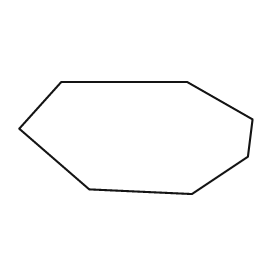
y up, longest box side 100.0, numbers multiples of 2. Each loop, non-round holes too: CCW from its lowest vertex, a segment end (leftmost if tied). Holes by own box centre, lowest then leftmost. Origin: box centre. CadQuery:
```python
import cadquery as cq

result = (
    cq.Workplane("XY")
    .moveTo(24.0, -24.0)
    .lineTo(48.0, -8.0)
    .lineTo(50.0, 8.0)
    .lineTo(22.0, 24.0)
    .lineTo(-32.0, 24.0)
    .lineTo(-50.0, 4.0)
    .lineTo(-20.0, -22.0)
    .close()
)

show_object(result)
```